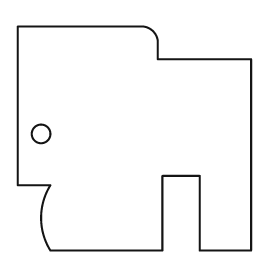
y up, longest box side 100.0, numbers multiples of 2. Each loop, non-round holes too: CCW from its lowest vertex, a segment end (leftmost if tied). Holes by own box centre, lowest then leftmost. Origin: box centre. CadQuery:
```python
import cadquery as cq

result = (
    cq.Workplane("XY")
    .moveTo(-36.0, -48.0)
    .lineTo(12.0, -48.0)
    .lineTo(12.0, -16.0)
    .lineTo(28.0, -16.0)
    .lineTo(28.0, -48.0)
    .lineTo(50.0, -48.0)
    .lineTo(50.0, 34.0)
    .lineTo(10.0, 34.0)
    .lineTo(10.0, 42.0)
    .threePointArc((8.0, 46.0), (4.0, 48.0))
    .lineTo(-50.0, 48.0)
    .lineTo(-50.0, -20.0)
    .lineTo(-36.0, -20.0)
    .threePointArc((-40.0, -34.0), (-36.0, -48.0))
    .close()
    .moveTo(-40.0, 2.0)
    .circle(4.0)
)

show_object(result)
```